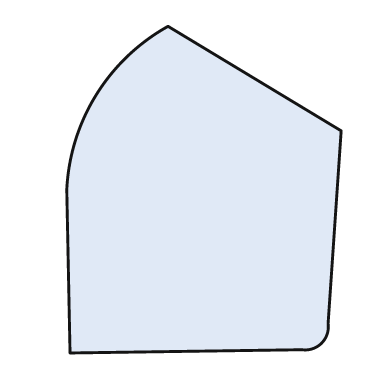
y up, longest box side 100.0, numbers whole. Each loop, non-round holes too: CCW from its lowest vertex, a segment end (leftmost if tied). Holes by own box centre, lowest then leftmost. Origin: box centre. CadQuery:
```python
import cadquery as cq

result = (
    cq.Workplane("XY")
    .moveTo(-41.0, -50.0)
    .lineTo(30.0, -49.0)
    .threePointArc((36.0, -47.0), (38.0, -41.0))
    .lineTo(42.0, 18.0)
    .lineTo(-11.0, 50.0)
    .threePointArc((-33.0, 29.0), (-42.0, 0.0))
    .close()
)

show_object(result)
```